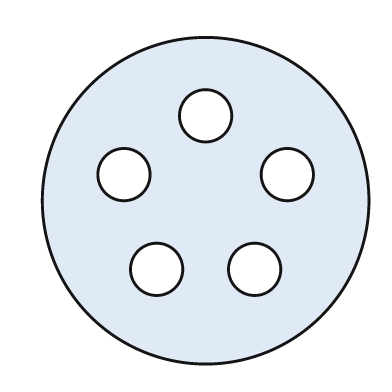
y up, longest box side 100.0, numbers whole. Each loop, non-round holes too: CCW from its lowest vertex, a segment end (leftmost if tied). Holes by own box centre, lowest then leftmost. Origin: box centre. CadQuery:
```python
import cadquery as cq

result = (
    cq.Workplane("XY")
    .moveTo(0.0, 0.0)
    .circle(50.0)
    .moveTo(-15.0, -21.0)
    .circle(8.0)
    .moveTo(15.0, -21.0)
    .circle(8.0)
    .moveTo(-25.0, 8.0)
    .circle(8.0)
    .moveTo(25.0, 8.0)
    .circle(8.0)
    .moveTo(0.0, 26.0)
    .circle(8.0)
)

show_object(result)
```